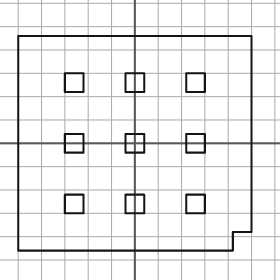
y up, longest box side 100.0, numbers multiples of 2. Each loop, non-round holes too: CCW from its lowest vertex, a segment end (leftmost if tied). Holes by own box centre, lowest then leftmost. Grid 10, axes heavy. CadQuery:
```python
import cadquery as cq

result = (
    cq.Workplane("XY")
    .moveTo(-50.0, -46.0)
    .lineTo(42.0, -46.0)
    .lineTo(42.0, -38.0)
    .lineTo(50.0, -38.0)
    .lineTo(50.0, 46.0)
    .lineTo(-50.0, 46.0)
    .close()
    .moveTo(-30.0, -30.0)
    .lineTo(-22.0, -30.0)
    .lineTo(-22.0, -22.0)
    .lineTo(-30.0, -22.0)
    .close()
    .moveTo(-4.0, -30.0)
    .lineTo(4.0, -30.0)
    .lineTo(4.0, -22.0)
    .lineTo(-4.0, -22.0)
    .close()
    .moveTo(22.0, -30.0)
    .lineTo(30.0, -30.0)
    .lineTo(30.0, -22.0)
    .lineTo(22.0, -22.0)
    .close()
    .moveTo(-30.0, -4.0)
    .lineTo(-22.0, -4.0)
    .lineTo(-22.0, 4.0)
    .lineTo(-30.0, 4.0)
    .close()
    .moveTo(-4.0, -4.0)
    .lineTo(4.0, -4.0)
    .lineTo(4.0, 4.0)
    .lineTo(-4.0, 4.0)
    .close()
    .moveTo(22.0, -4.0)
    .lineTo(30.0, -4.0)
    .lineTo(30.0, 4.0)
    .lineTo(22.0, 4.0)
    .close()
    .moveTo(-30.0, 22.0)
    .lineTo(-22.0, 22.0)
    .lineTo(-22.0, 30.0)
    .lineTo(-30.0, 30.0)
    .close()
    .moveTo(-4.0, 22.0)
    .lineTo(4.0, 22.0)
    .lineTo(4.0, 30.0)
    .lineTo(-4.0, 30.0)
    .close()
    .moveTo(22.0, 22.0)
    .lineTo(30.0, 22.0)
    .lineTo(30.0, 30.0)
    .lineTo(22.0, 30.0)
    .close()
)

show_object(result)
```